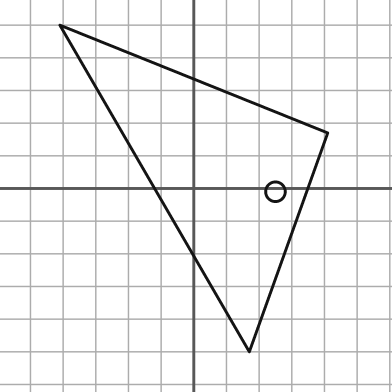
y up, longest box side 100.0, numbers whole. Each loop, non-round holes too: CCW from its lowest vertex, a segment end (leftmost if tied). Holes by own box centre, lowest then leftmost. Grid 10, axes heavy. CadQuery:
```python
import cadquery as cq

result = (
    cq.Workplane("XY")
    .moveTo(17.0, -50.0)
    .lineTo(41.0, 17.0)
    .lineTo(-41.0, 50.0)
    .close()
    .moveTo(25.0, -1.0)
    .circle(3.0)
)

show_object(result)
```